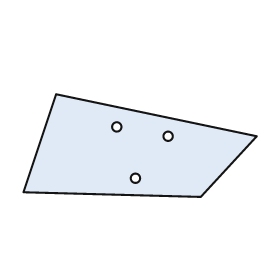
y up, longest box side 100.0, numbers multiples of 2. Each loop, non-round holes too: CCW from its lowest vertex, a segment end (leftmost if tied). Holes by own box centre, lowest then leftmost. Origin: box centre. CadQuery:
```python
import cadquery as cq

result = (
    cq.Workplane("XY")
    .moveTo(26.0, -22.0)
    .lineTo(50.0, 4.0)
    .lineTo(-36.0, 22.0)
    .lineTo(-50.0, -20.0)
    .close()
    .moveTo(-2.0, -14.0)
    .circle(2.0)
    .moveTo(12.0, 4.0)
    .circle(2.0)
    .moveTo(-10.0, 8.0)
    .circle(2.0)
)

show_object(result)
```